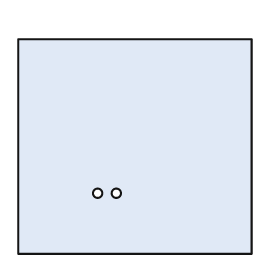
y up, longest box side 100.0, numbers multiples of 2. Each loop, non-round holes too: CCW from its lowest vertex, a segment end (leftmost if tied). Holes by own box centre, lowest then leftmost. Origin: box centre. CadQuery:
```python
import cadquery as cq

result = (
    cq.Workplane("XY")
    .moveTo(-50.0, -46.0)
    .lineTo(50.0, -46.0)
    .lineTo(50.0, 46.0)
    .lineTo(-50.0, 46.0)
    .close()
    .moveTo(-16.0, -20.0)
    .circle(2.0)
    .moveTo(-8.0, -20.0)
    .circle(2.0)
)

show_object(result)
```